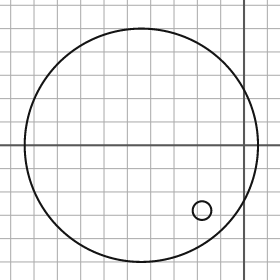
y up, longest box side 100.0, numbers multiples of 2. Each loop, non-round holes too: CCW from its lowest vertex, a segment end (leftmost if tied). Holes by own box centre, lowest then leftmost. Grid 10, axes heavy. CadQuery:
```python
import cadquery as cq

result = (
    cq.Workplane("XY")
    .moveTo(-44.0, 0.0)
    .circle(50.0)
    .moveTo(-18.0, -28.0)
    .circle(4.0)
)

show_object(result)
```